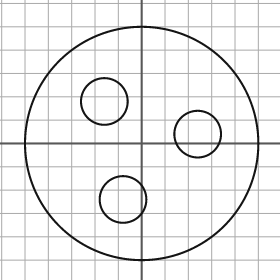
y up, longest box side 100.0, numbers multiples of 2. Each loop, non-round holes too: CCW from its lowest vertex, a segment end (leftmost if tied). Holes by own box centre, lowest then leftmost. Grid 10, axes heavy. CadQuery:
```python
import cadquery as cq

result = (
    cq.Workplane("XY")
    .moveTo(0.0, 0.0)
    .circle(50.0)
    .moveTo(-8.0, -24.0)
    .circle(10.0)
    .moveTo(24.0, 4.0)
    .circle(10.0)
    .moveTo(-16.0, 18.0)
    .circle(10.0)
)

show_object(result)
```